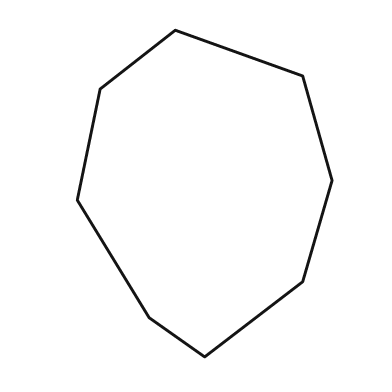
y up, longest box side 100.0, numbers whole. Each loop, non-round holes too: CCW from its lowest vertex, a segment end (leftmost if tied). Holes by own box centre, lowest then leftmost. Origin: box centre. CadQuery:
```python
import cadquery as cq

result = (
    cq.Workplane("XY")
    .moveTo(0.0, -50.0)
    .lineTo(30.0, -27.0)
    .lineTo(39.0, 4.0)
    .lineTo(30.0, 36.0)
    .lineTo(-9.0, 50.0)
    .lineTo(-32.0, 32.0)
    .lineTo(-39.0, -2.0)
    .lineTo(-17.0, -38.0)
    .close()
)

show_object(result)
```